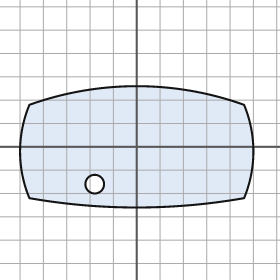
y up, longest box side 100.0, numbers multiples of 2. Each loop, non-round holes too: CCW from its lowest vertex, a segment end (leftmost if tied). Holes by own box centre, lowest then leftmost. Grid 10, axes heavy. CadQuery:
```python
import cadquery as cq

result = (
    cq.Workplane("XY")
    .moveTo(-46.0, -22.0)
    .threePointArc((0.0, -26.0), (46.0, -22.0))
    .threePointArc((50.0, -2.0), (46.0, 18.0))
    .threePointArc((0.0, 26.0), (-46.0, 18.0))
    .threePointArc((-50.0, -2.0), (-46.0, -22.0))
    .close()
    .moveTo(-18.0, -16.0)
    .circle(4.0)
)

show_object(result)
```